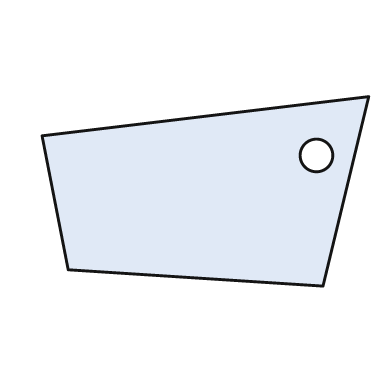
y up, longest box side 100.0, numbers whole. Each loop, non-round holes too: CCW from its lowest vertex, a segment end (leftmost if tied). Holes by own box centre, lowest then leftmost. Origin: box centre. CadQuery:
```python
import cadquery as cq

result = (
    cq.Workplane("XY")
    .moveTo(36.0, -29.0)
    .lineTo(50.0, 29.0)
    .lineTo(-50.0, 17.0)
    .lineTo(-42.0, -24.0)
    .close()
    .moveTo(34.0, 11.0)
    .circle(5.0)
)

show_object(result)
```